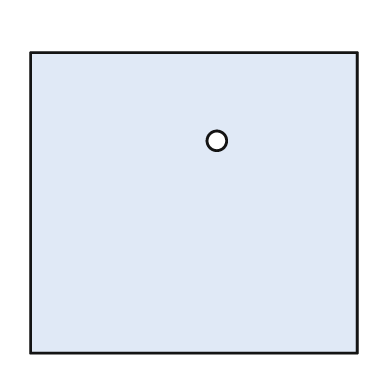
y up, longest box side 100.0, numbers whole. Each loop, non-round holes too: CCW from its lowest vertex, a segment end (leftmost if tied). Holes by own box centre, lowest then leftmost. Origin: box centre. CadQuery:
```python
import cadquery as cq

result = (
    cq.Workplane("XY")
    .moveTo(-50.0, -46.0)
    .lineTo(50.0, -46.0)
    .lineTo(50.0, 46.0)
    .lineTo(-50.0, 46.0)
    .close()
    .moveTo(7.0, 19.0)
    .circle(3.0)
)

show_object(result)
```